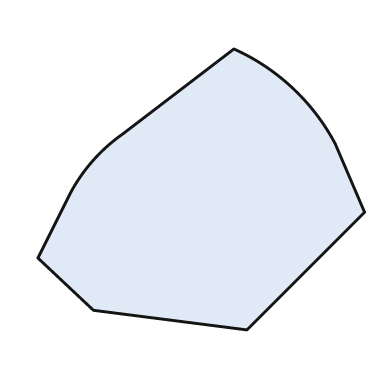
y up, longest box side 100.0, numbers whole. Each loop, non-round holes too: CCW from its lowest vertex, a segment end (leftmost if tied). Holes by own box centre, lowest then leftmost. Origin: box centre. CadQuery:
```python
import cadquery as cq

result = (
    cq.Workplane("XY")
    .moveTo(14.0, -43.0)
    .lineTo(50.0, -7.0)
    .lineTo(41.0, 14.0)
    .threePointArc((28.0, 31.0), (10.0, 43.0))
    .lineTo(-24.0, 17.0)
    .threePointArc((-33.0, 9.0), (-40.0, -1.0))
    .lineTo(-50.0, -21.0)
    .lineTo(-33.0, -37.0)
    .close()
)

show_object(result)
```